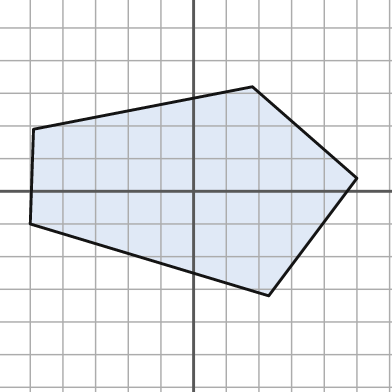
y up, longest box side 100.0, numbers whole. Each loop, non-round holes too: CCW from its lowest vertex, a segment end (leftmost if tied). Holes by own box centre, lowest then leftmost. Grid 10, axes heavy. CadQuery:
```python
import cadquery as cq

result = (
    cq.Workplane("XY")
    .moveTo(23.0, -32.0)
    .lineTo(50.0, 4.0)
    .lineTo(18.0, 32.0)
    .lineTo(-49.0, 19.0)
    .lineTo(-50.0, -10.0)
    .close()
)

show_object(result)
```